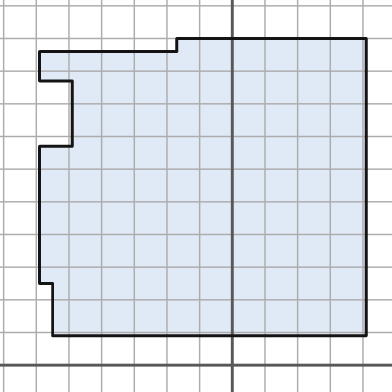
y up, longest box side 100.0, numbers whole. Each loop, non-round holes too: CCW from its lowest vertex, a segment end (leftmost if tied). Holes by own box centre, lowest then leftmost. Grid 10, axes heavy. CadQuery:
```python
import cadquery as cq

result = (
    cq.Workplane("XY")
    .moveTo(-55.0, 9.0)
    .lineTo(41.0, 9.0)
    .lineTo(41.0, 100.0)
    .lineTo(-17.0, 100.0)
    .lineTo(-17.0, 96.0)
    .lineTo(-59.0, 96.0)
    .lineTo(-59.0, 87.0)
    .lineTo(-49.0, 87.0)
    .lineTo(-49.0, 67.0)
    .lineTo(-59.0, 67.0)
    .lineTo(-59.0, 25.0)
    .lineTo(-55.0, 25.0)
    .close()
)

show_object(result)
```